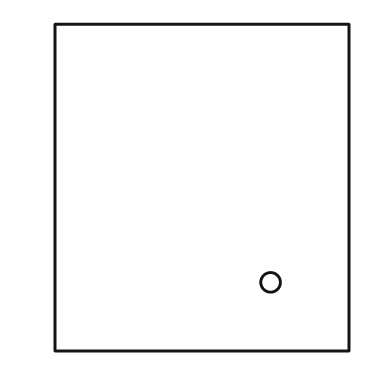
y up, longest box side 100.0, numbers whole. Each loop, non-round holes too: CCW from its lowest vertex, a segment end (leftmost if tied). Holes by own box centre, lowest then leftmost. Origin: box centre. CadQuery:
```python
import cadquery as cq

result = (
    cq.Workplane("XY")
    .moveTo(-45.0, -50.0)
    .lineTo(45.0, -50.0)
    .lineTo(45.0, 50.0)
    .lineTo(-45.0, 50.0)
    .close()
    .moveTo(21.0, -29.0)
    .circle(3.0)
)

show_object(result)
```